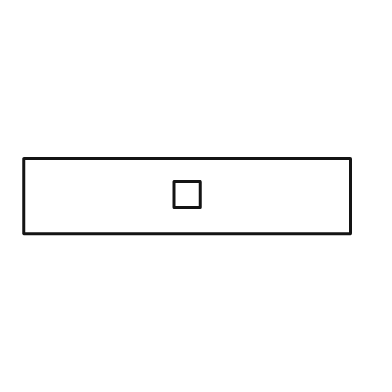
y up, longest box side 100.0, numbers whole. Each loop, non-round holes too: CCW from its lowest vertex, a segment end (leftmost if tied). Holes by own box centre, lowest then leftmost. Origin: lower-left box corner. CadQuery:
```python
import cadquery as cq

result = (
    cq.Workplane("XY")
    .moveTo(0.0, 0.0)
    .lineTo(100.0, 0.0)
    .lineTo(100.0, 23.0)
    .lineTo(0.0, 23.0)
    .close()
    .moveTo(46.0, 8.0)
    .lineTo(54.0, 8.0)
    .lineTo(54.0, 16.0)
    .lineTo(46.0, 16.0)
    .close()
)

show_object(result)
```